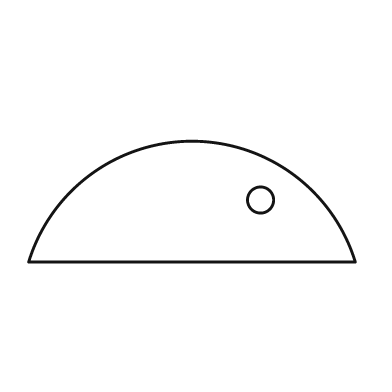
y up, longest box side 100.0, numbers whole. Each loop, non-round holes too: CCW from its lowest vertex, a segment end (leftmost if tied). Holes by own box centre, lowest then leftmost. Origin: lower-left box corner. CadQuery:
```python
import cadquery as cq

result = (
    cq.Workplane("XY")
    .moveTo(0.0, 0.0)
    .lineTo(100.0, 0.0)
    .threePointArc((50.0, 37.0), (0.0, 0.0))
    .close()
    .moveTo(71.0, 19.0)
    .circle(4.0)
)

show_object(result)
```